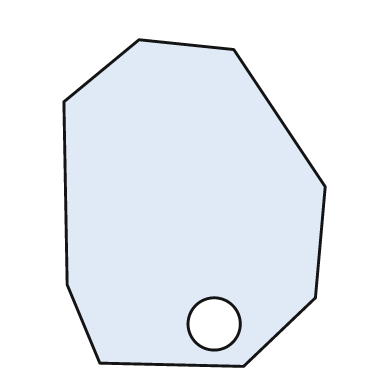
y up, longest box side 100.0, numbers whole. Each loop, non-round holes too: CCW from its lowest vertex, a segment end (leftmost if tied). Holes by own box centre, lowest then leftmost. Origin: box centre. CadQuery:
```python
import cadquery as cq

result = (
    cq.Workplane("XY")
    .moveTo(15.0, -50.0)
    .lineTo(37.0, -29.0)
    .lineTo(40.0, 5.0)
    .lineTo(12.0, 47.0)
    .lineTo(-17.0, 50.0)
    .lineTo(-40.0, 31.0)
    .lineTo(-39.0, -25.0)
    .lineTo(-29.0, -49.0)
    .close()
    .moveTo(6.0, -37.0)
    .circle(8.0)
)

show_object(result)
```